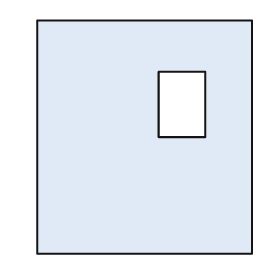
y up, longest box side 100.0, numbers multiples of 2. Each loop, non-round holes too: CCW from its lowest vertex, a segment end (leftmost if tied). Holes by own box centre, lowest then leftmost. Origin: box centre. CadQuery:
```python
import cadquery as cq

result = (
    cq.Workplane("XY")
    .moveTo(-46.0, -50.0)
    .lineTo(46.0, -50.0)
    .lineTo(46.0, 50.0)
    .lineTo(-46.0, 50.0)
    .close()
    .moveTo(6.0, 0.0)
    .lineTo(26.0, 0.0)
    .lineTo(26.0, 28.0)
    .lineTo(6.0, 28.0)
    .close()
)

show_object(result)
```